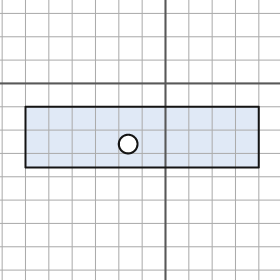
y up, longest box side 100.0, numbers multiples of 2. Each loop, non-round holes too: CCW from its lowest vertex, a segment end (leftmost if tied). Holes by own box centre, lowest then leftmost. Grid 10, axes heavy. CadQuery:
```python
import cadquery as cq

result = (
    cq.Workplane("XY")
    .moveTo(-60.0, -36.0)
    .lineTo(40.0, -36.0)
    .lineTo(40.0, -10.0)
    .lineTo(-60.0, -10.0)
    .close()
    .moveTo(-16.0, -26.0)
    .circle(4.0)
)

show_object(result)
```